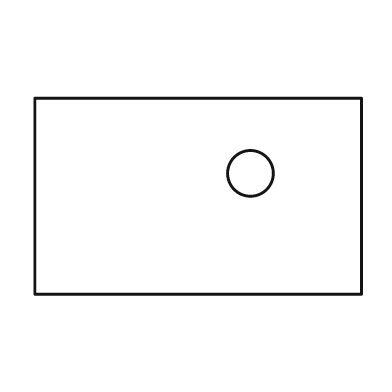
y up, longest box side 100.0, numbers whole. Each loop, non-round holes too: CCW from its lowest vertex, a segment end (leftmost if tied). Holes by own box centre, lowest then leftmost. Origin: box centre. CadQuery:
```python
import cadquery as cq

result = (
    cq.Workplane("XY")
    .moveTo(-50.0, -30.0)
    .lineTo(50.0, -30.0)
    .lineTo(50.0, 30.0)
    .lineTo(-50.0, 30.0)
    .close()
    .moveTo(16.0, 7.0)
    .circle(7.0)
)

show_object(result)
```